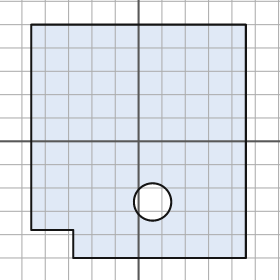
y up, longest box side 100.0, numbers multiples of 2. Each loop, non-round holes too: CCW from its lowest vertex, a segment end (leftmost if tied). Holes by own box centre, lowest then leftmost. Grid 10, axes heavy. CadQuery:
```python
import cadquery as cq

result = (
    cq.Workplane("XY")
    .moveTo(-28.0, -50.0)
    .lineTo(46.0, -50.0)
    .lineTo(46.0, 50.0)
    .lineTo(-46.0, 50.0)
    .lineTo(-46.0, -38.0)
    .lineTo(-28.0, -38.0)
    .close()
    .moveTo(6.0, -26.0)
    .circle(8.0)
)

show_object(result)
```